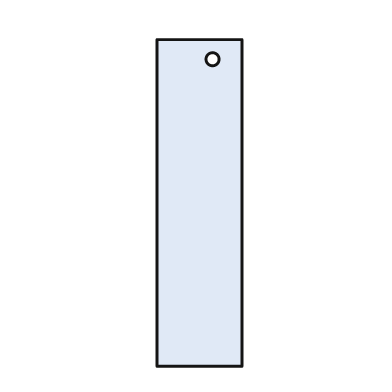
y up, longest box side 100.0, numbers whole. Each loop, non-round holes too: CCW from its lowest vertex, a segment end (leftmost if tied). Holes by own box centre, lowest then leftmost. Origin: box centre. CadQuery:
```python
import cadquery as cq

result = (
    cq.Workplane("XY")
    .moveTo(-13.0, -50.0)
    .lineTo(13.0, -50.0)
    .lineTo(13.0, 50.0)
    .lineTo(-13.0, 50.0)
    .close()
    .moveTo(4.0, 44.0)
    .circle(2.0)
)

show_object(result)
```